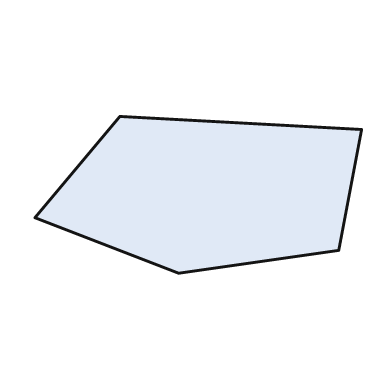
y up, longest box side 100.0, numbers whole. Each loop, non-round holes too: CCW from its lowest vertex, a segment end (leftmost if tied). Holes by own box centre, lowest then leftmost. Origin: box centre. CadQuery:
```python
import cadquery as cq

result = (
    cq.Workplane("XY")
    .moveTo(-6.0, -24.0)
    .lineTo(43.0, -17.0)
    .lineTo(50.0, 20.0)
    .lineTo(-24.0, 24.0)
    .lineTo(-50.0, -7.0)
    .close()
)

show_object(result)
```